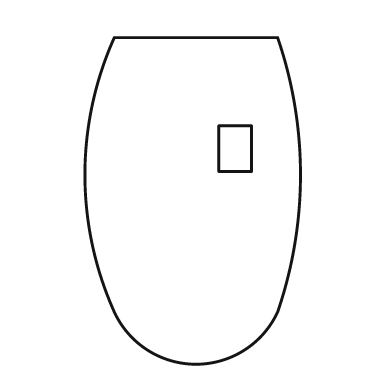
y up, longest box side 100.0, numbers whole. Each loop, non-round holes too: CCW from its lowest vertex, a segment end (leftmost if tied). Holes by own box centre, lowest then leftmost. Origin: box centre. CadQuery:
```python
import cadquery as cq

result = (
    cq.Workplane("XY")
    .moveTo(-24.0, -34.0)
    .threePointArc((1.0, -50.0), (26.0, -34.0))
    .threePointArc((33.0, 8.0), (26.0, 50.0))
    .lineTo(-24.0, 50.0)
    .threePointArc((-33.0, 8.0), (-24.0, -34.0))
    .close()
    .moveTo(8.0, 9.0)
    .lineTo(18.0, 9.0)
    .lineTo(18.0, 23.0)
    .lineTo(8.0, 23.0)
    .close()
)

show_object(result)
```